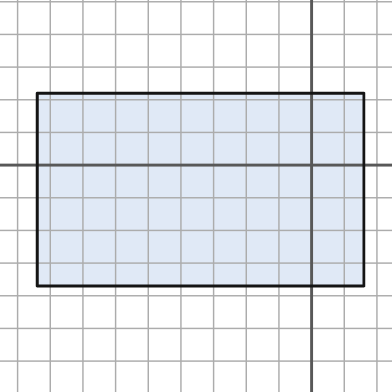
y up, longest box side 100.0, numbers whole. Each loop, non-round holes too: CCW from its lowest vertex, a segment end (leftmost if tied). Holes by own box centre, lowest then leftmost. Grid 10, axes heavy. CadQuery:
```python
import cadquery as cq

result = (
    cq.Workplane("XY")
    .moveTo(-84.0, -37.0)
    .lineTo(16.0, -37.0)
    .lineTo(16.0, 22.0)
    .lineTo(-84.0, 22.0)
    .close()
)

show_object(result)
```